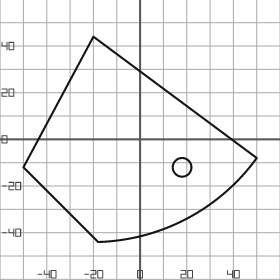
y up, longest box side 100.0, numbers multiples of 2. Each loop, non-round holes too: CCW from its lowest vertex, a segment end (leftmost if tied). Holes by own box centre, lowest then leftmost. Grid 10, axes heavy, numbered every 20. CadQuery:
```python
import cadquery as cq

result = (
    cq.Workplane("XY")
    .moveTo(-18.0, -44.0)
    .threePointArc((20.0, -34.0), (50.0, -8.0))
    .lineTo(-20.0, 44.0)
    .lineTo(-50.0, -12.0)
    .close()
    .moveTo(18.0, -12.0)
    .circle(4.0)
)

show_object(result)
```